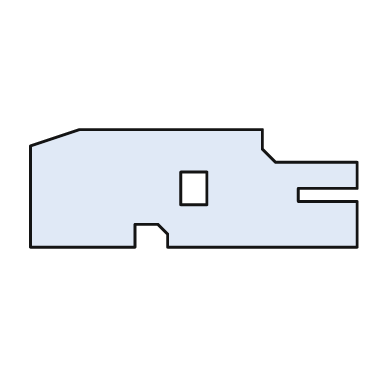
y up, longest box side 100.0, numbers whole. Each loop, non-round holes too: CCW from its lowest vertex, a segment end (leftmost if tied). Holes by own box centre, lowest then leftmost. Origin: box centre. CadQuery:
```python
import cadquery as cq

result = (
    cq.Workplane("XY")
    .moveTo(-50.0, -18.0)
    .lineTo(-18.0, -18.0)
    .lineTo(-18.0, -11.0)
    .lineTo(-11.0, -11.0)
    .lineTo(-8.0, -14.0)
    .lineTo(-8.0, -18.0)
    .lineTo(50.0, -18.0)
    .lineTo(50.0, -4.0)
    .lineTo(32.0, -4.0)
    .lineTo(32.0, 0.0)
    .lineTo(50.0, 0.0)
    .lineTo(50.0, 8.0)
    .lineTo(25.0, 8.0)
    .lineTo(21.0, 12.0)
    .lineTo(21.0, 18.0)
    .lineTo(-35.0, 18.0)
    .lineTo(-50.0, 13.0)
    .close()
    .moveTo(-4.0, -5.0)
    .lineTo(4.0, -5.0)
    .lineTo(4.0, 5.0)
    .lineTo(-4.0, 5.0)
    .close()
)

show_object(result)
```